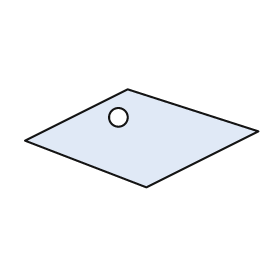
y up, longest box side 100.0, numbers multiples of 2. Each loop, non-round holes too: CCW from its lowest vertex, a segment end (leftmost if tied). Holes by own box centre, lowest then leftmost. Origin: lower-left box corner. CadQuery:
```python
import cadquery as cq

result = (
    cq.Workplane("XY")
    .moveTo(52.0, 0.0)
    .lineTo(100.0, 24.0)
    .lineTo(44.0, 42.0)
    .lineTo(0.0, 20.0)
    .close()
    .moveTo(40.0, 30.0)
    .circle(4.0)
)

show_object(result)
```